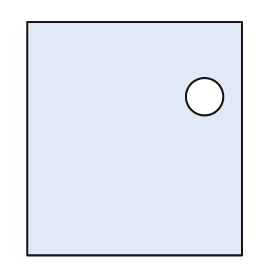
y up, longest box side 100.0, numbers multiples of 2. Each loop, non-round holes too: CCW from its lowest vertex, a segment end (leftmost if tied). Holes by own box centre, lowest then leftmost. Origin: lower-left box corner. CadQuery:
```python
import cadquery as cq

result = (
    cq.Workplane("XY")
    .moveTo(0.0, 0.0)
    .lineTo(92.0, 0.0)
    .lineTo(92.0, 100.0)
    .lineTo(0.0, 100.0)
    .close()
    .moveTo(76.0, 68.0)
    .circle(8.0)
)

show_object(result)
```